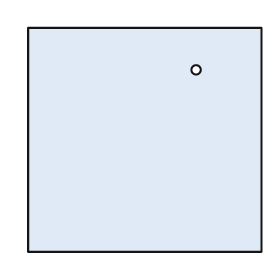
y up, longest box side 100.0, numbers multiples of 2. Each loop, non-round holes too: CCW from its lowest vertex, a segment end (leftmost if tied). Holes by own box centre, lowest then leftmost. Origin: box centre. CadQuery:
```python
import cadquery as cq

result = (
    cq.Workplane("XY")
    .moveTo(-50.0, -48.0)
    .lineTo(50.0, -48.0)
    .lineTo(50.0, 48.0)
    .lineTo(-50.0, 48.0)
    .close()
    .moveTo(22.0, 30.0)
    .circle(2.0)
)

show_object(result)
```